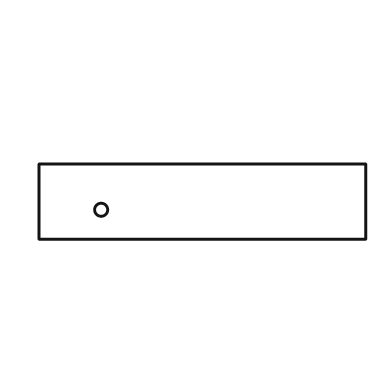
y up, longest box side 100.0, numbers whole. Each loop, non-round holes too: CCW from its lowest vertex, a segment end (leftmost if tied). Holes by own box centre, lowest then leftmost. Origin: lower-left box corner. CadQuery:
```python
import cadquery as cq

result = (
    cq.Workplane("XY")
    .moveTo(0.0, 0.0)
    .lineTo(100.0, 0.0)
    .lineTo(100.0, 23.0)
    .lineTo(0.0, 23.0)
    .close()
    .moveTo(19.0, 9.0)
    .circle(2.0)
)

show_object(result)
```